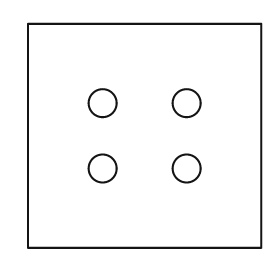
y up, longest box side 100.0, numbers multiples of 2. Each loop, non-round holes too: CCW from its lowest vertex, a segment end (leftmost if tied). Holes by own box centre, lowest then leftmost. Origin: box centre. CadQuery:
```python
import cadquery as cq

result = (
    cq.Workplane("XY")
    .moveTo(-50.0, -48.0)
    .lineTo(50.0, -48.0)
    .lineTo(50.0, 48.0)
    .lineTo(-50.0, 48.0)
    .close()
    .moveTo(-18.0, -14.0)
    .circle(6.0)
    .moveTo(18.0, -14.0)
    .circle(6.0)
    .moveTo(-18.0, 14.0)
    .circle(6.0)
    .moveTo(18.0, 14.0)
    .circle(6.0)
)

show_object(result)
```